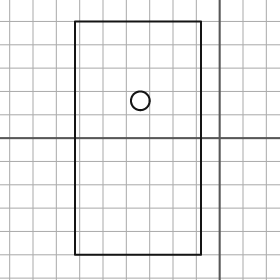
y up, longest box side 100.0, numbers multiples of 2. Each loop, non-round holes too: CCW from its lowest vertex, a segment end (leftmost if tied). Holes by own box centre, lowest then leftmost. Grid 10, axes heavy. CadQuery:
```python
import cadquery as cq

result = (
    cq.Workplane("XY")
    .moveTo(-62.0, -50.0)
    .lineTo(-8.0, -50.0)
    .lineTo(-8.0, 50.0)
    .lineTo(-62.0, 50.0)
    .close()
    .moveTo(-34.0, 16.0)
    .circle(4.0)
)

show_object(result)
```